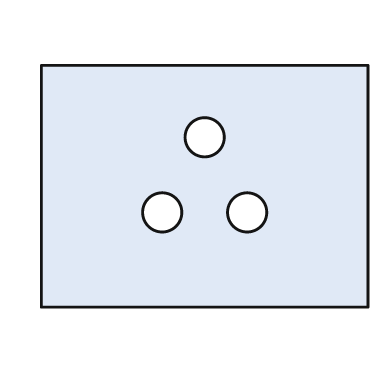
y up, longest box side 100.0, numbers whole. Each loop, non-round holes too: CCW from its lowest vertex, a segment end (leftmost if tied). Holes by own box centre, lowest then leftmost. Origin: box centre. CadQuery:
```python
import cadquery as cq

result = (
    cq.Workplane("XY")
    .moveTo(-50.0, -37.0)
    .lineTo(50.0, -37.0)
    .lineTo(50.0, 37.0)
    .lineTo(-50.0, 37.0)
    .close()
    .moveTo(-13.0, -8.0)
    .circle(6.0)
    .moveTo(13.0, -8.0)
    .circle(6.0)
    .moveTo(0.0, 15.0)
    .circle(6.0)
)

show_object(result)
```